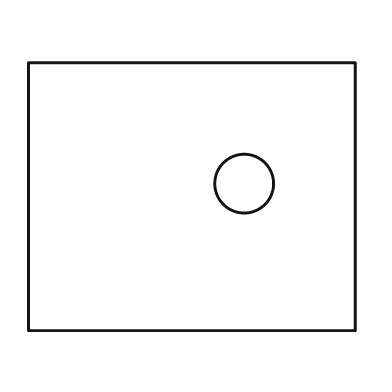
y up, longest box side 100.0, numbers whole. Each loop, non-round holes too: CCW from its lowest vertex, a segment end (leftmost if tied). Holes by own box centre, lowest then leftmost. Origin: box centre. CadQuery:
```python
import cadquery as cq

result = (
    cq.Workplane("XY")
    .moveTo(-50.0, -41.0)
    .lineTo(50.0, -41.0)
    .lineTo(50.0, 41.0)
    .lineTo(-50.0, 41.0)
    .close()
    .moveTo(16.0, 4.0)
    .circle(9.0)
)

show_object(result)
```